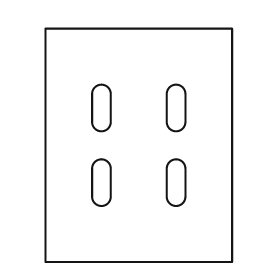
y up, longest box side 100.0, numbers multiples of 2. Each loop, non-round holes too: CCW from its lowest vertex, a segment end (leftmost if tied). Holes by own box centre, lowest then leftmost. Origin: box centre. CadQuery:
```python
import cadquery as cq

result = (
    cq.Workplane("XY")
    .moveTo(-40.0, -50.0)
    .lineTo(40.0, -50.0)
    .lineTo(40.0, 50.0)
    .lineTo(-40.0, 50.0)
    .close()
    .moveTo(-20.0, -22.0)
    .threePointArc((-16.0, -26.0), (-12.0, -22.0))
    .lineTo(-12.0, -10.0)
    .threePointArc((-16.0, -6.0), (-20.0, -10.0))
    .close()
    .moveTo(12.0, -22.0)
    .threePointArc((16.0, -26.0), (20.0, -22.0))
    .lineTo(20.0, -10.0)
    .threePointArc((16.0, -6.0), (12.0, -10.0))
    .close()
    .moveTo(-20.0, 10.0)
    .threePointArc((-16.0, 6.0), (-12.0, 10.0))
    .lineTo(-12.0, 22.0)
    .threePointArc((-16.0, 26.0), (-20.0, 22.0))
    .close()
    .moveTo(12.0, 10.0)
    .threePointArc((16.0, 6.0), (20.0, 10.0))
    .lineTo(20.0, 22.0)
    .threePointArc((16.0, 26.0), (12.0, 22.0))
    .close()
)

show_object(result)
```